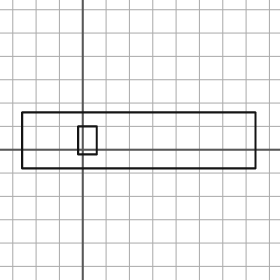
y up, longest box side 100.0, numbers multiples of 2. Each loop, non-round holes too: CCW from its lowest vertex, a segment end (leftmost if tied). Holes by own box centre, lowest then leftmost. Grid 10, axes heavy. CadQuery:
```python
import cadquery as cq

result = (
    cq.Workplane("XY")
    .moveTo(-26.0, -8.0)
    .lineTo(74.0, -8.0)
    .lineTo(74.0, 16.0)
    .lineTo(-26.0, 16.0)
    .close()
    .moveTo(-2.0, -2.0)
    .lineTo(6.0, -2.0)
    .lineTo(6.0, 10.0)
    .lineTo(-2.0, 10.0)
    .close()
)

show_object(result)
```